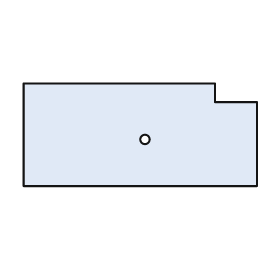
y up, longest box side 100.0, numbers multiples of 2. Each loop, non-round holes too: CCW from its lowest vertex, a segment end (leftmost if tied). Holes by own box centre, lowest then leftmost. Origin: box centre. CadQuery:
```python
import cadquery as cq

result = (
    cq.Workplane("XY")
    .moveTo(-50.0, -22.0)
    .lineTo(50.0, -22.0)
    .lineTo(50.0, 14.0)
    .lineTo(32.0, 14.0)
    .lineTo(32.0, 22.0)
    .lineTo(-50.0, 22.0)
    .close()
    .moveTo(2.0, -2.0)
    .circle(2.0)
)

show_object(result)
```